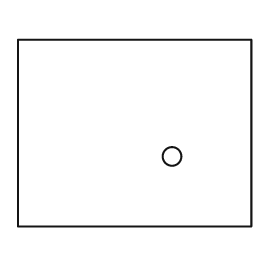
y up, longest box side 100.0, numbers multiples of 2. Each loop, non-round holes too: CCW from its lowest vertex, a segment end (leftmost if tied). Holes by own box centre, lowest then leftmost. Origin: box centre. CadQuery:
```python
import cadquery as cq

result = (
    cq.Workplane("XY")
    .moveTo(-50.0, -40.0)
    .lineTo(50.0, -40.0)
    .lineTo(50.0, 40.0)
    .lineTo(-50.0, 40.0)
    .close()
    .moveTo(16.0, -10.0)
    .circle(4.0)
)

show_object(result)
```